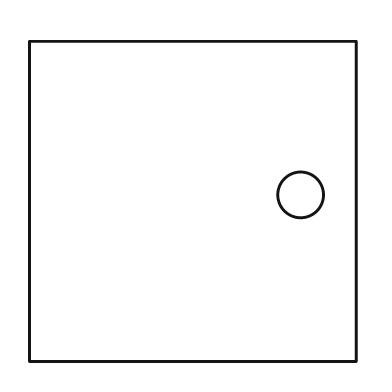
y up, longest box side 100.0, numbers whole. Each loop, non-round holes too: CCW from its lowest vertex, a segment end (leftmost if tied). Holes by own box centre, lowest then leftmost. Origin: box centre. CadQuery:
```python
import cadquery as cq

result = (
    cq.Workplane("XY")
    .moveTo(-50.0, -49.0)
    .lineTo(50.0, -49.0)
    .lineTo(50.0, 49.0)
    .lineTo(-50.0, 49.0)
    .close()
    .moveTo(33.0, 2.0)
    .circle(7.0)
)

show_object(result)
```